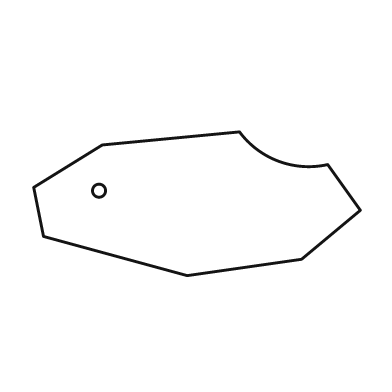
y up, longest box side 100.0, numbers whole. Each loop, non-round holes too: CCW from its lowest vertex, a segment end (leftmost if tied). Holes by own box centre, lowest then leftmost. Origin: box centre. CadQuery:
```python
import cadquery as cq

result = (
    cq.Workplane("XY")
    .moveTo(-3.0, -22.0)
    .lineTo(32.0, -17.0)
    .lineTo(50.0, -2.0)
    .lineTo(40.0, 12.0)
    .threePointArc((25.0, 13.0), (13.0, 22.0))
    .lineTo(-29.0, 18.0)
    .lineTo(-50.0, 5.0)
    .lineTo(-47.0, -10.0)
    .close()
    .moveTo(-30.0, 4.0)
    .circle(2.0)
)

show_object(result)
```